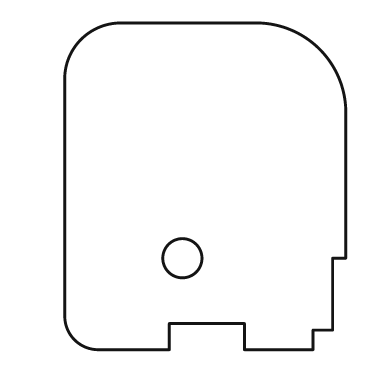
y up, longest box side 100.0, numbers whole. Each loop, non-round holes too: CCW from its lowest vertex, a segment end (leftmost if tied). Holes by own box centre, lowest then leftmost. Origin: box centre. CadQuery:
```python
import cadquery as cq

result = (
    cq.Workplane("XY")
    .moveTo(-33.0, -50.0)
    .lineTo(-11.0, -50.0)
    .lineTo(-11.0, -42.0)
    .lineTo(12.0, -42.0)
    .lineTo(12.0, -50.0)
    .lineTo(33.0, -50.0)
    .lineTo(33.0, -44.0)
    .lineTo(39.0, -44.0)
    .lineTo(39.0, -22.0)
    .lineTo(43.0, -22.0)
    .lineTo(43.0, 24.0)
    .threePointArc((35.0, 42.0), (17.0, 50.0))
    .lineTo(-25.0, 50.0)
    .threePointArc((-38.0, 45.0), (-43.0, 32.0))
    .lineTo(-43.0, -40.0)
    .threePointArc((-40.0, -47.0), (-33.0, -50.0))
    .close()
    .moveTo(-7.0, -22.0)
    .circle(6.0)
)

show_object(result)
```